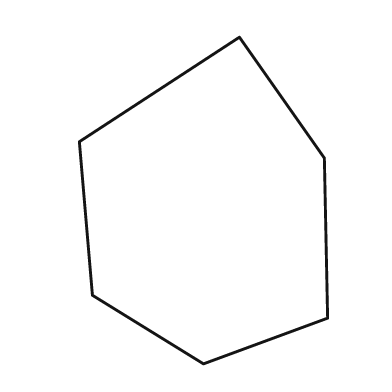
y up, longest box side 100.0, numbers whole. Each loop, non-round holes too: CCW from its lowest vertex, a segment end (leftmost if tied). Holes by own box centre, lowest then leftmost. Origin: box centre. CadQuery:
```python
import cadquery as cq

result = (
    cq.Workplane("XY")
    .moveTo(0.0, -50.0)
    .lineTo(38.0, -36.0)
    .lineTo(37.0, 13.0)
    .lineTo(11.0, 50.0)
    .lineTo(-38.0, 18.0)
    .lineTo(-34.0, -29.0)
    .close()
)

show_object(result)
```